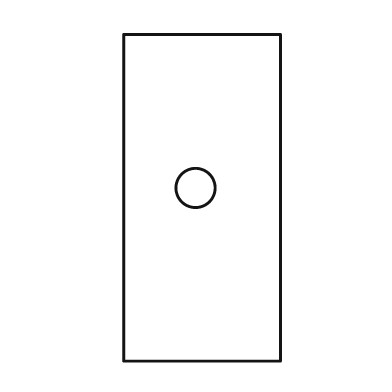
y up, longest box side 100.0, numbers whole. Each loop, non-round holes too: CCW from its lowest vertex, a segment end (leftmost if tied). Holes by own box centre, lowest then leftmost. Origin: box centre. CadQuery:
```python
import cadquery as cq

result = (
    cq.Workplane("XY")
    .moveTo(-24.0, -50.0)
    .lineTo(24.0, -50.0)
    .lineTo(24.0, 50.0)
    .lineTo(-24.0, 50.0)
    .close()
    .moveTo(-2.0, 3.0)
    .circle(6.0)
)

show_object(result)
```